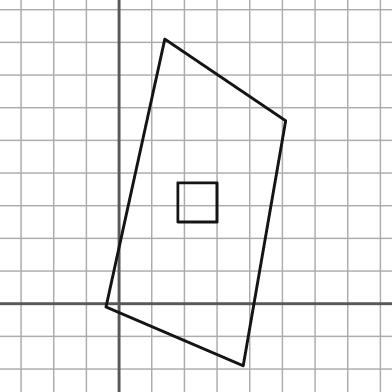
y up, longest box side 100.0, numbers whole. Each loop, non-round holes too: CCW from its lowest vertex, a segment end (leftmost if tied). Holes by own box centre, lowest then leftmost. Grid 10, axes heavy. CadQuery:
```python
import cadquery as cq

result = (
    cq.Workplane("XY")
    .moveTo(38.0, -19.0)
    .lineTo(51.0, 56.0)
    .lineTo(14.0, 81.0)
    .lineTo(-4.0, -1.0)
    .close()
    .moveTo(18.0, 25.0)
    .lineTo(30.0, 25.0)
    .lineTo(30.0, 37.0)
    .lineTo(18.0, 37.0)
    .close()
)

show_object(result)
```